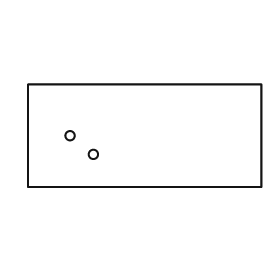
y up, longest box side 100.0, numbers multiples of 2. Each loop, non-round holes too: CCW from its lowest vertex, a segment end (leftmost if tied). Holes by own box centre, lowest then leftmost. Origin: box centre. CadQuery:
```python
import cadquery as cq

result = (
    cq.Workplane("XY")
    .moveTo(-50.0, -22.0)
    .lineTo(50.0, -22.0)
    .lineTo(50.0, 22.0)
    .lineTo(-50.0, 22.0)
    .close()
    .moveTo(-22.0, -8.0)
    .circle(2.0)
    .moveTo(-32.0, 0.0)
    .circle(2.0)
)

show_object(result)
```